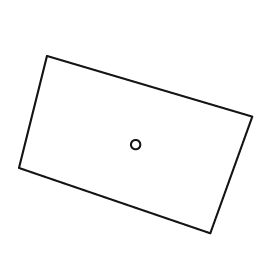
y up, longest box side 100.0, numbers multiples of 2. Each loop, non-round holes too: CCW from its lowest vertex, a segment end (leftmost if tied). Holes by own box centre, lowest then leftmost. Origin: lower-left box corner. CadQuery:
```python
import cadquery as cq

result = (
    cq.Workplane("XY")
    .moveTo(82.0, 0.0)
    .lineTo(100.0, 50.0)
    .lineTo(12.0, 76.0)
    .lineTo(0.0, 28.0)
    .close()
    .moveTo(50.0, 38.0)
    .circle(2.0)
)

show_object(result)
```